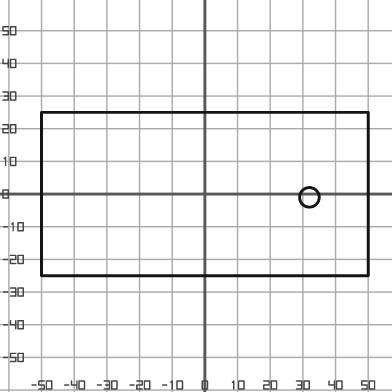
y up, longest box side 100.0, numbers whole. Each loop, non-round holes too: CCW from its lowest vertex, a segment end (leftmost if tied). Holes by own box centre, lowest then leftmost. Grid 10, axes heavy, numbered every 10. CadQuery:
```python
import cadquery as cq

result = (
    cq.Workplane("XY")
    .moveTo(-50.0, -25.0)
    .lineTo(50.0, -25.0)
    .lineTo(50.0, 25.0)
    .lineTo(-50.0, 25.0)
    .close()
    .moveTo(32.0, -1.0)
    .circle(3.0)
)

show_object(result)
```